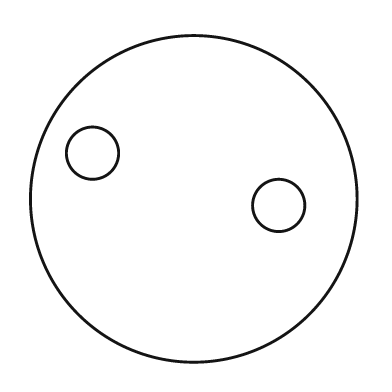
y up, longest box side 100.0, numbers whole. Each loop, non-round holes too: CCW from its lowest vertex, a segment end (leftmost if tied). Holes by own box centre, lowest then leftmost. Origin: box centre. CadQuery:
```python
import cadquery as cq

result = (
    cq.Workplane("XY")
    .moveTo(0.0, 0.0)
    .circle(50.0)
    .moveTo(26.0, -2.0)
    .circle(8.0)
    .moveTo(-31.0, 14.0)
    .circle(8.0)
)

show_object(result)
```